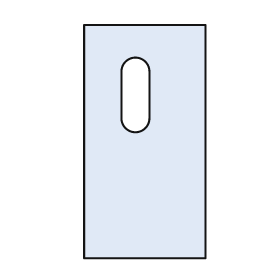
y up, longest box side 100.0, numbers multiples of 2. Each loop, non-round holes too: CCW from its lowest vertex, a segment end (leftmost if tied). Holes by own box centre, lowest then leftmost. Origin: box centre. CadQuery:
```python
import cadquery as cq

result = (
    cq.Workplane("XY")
    .moveTo(-26.0, -50.0)
    .lineTo(26.0, -50.0)
    .lineTo(26.0, 50.0)
    .lineTo(-26.0, 50.0)
    .close()
    .moveTo(-10.0, 10.0)
    .threePointArc((-4.0, 4.0), (2.0, 10.0))
    .lineTo(2.0, 30.0)
    .threePointArc((-4.0, 36.0), (-10.0, 30.0))
    .close()
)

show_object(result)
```